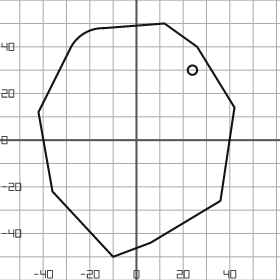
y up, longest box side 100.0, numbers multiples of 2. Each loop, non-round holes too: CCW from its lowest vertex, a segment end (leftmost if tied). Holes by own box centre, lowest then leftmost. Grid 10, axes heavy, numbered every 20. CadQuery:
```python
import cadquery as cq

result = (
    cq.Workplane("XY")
    .moveTo(-10.0, -50.0)
    .lineTo(6.0, -44.0)
    .lineTo(36.0, -26.0)
    .lineTo(42.0, 14.0)
    .lineTo(26.0, 40.0)
    .lineTo(12.0, 50.0)
    .lineTo(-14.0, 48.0)
    .threePointArc((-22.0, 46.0), (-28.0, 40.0))
    .lineTo(-42.0, 12.0)
    .lineTo(-36.0, -22.0)
    .close()
    .moveTo(24.0, 30.0)
    .circle(2.0)
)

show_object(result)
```